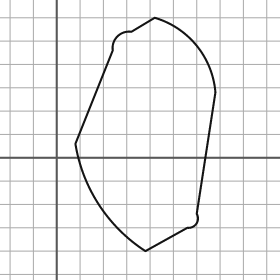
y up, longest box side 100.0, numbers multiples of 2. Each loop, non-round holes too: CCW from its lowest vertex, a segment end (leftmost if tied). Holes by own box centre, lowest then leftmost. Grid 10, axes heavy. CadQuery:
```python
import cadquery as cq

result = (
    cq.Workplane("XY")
    .moveTo(38.0, -40.0)
    .lineTo(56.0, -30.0)
    .threePointArc((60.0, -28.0), (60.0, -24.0))
    .lineTo(68.0, 28.0)
    .threePointArc((60.0, 48.0), (42.0, 60.0))
    .lineTo(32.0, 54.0)
    .threePointArc((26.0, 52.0), (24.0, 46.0))
    .lineTo(8.0, 6.0)
    .threePointArc((18.0, -20.0), (38.0, -40.0))
    .close()
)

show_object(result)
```